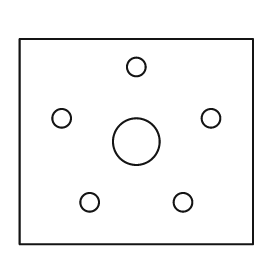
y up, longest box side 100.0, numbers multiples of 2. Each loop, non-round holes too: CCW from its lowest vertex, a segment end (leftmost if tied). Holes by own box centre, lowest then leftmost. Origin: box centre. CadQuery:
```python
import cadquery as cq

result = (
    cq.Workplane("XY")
    .moveTo(-50.0, -44.0)
    .lineTo(50.0, -44.0)
    .lineTo(50.0, 44.0)
    .lineTo(-50.0, 44.0)
    .close()
    .moveTo(-20.0, -26.0)
    .circle(4.0)
    .moveTo(20.0, -26.0)
    .circle(4.0)
    .moveTo(0.0, 0.0)
    .circle(10.0)
    .moveTo(-32.0, 10.0)
    .circle(4.0)
    .moveTo(32.0, 10.0)
    .circle(4.0)
    .moveTo(0.0, 32.0)
    .circle(4.0)
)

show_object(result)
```